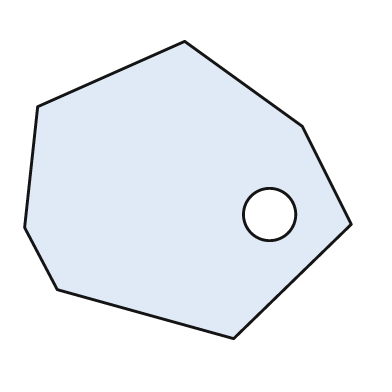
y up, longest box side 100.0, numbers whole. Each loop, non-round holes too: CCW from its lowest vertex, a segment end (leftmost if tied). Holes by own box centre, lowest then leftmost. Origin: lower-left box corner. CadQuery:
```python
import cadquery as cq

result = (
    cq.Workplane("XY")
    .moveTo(64.0, 0.0)
    .lineTo(100.0, 35.0)
    .lineTo(85.0, 65.0)
    .lineTo(49.0, 91.0)
    .lineTo(4.0, 71.0)
    .lineTo(0.0, 34.0)
    .lineTo(10.0, 15.0)
    .close()
    .moveTo(75.0, 38.0)
    .circle(8.0)
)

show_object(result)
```